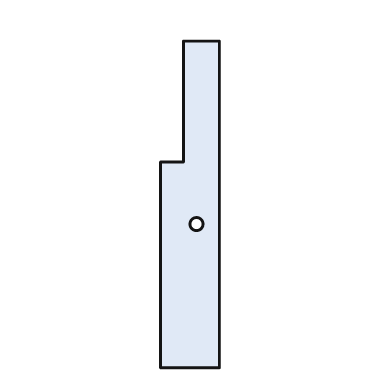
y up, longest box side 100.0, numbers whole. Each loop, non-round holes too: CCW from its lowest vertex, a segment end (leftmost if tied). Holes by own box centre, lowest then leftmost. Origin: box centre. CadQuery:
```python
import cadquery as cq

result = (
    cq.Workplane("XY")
    .moveTo(-9.0, -50.0)
    .lineTo(9.0, -50.0)
    .lineTo(9.0, 50.0)
    .lineTo(-2.0, 50.0)
    .lineTo(-2.0, 13.0)
    .lineTo(-9.0, 13.0)
    .close()
    .moveTo(2.0, -6.0)
    .circle(2.0)
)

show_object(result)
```